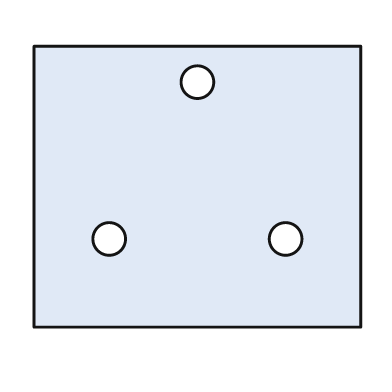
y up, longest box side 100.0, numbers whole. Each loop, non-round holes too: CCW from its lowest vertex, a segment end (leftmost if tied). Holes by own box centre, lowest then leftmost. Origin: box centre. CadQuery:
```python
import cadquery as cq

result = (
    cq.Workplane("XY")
    .moveTo(-50.0, -43.0)
    .lineTo(50.0, -43.0)
    .lineTo(50.0, 43.0)
    .lineTo(-50.0, 43.0)
    .close()
    .moveTo(-27.0, -16.0)
    .circle(5.0)
    .moveTo(27.0, -16.0)
    .circle(5.0)
    .moveTo(0.0, 32.0)
    .circle(5.0)
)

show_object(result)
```